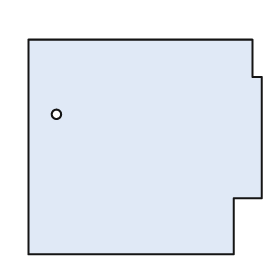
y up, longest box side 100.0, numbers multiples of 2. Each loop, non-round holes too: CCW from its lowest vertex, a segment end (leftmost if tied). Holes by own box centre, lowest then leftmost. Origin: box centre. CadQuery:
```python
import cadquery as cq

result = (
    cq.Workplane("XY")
    .moveTo(-50.0, -46.0)
    .lineTo(38.0, -46.0)
    .lineTo(38.0, -22.0)
    .lineTo(50.0, -22.0)
    .lineTo(50.0, 30.0)
    .lineTo(46.0, 30.0)
    .lineTo(46.0, 46.0)
    .lineTo(-50.0, 46.0)
    .close()
    .moveTo(-38.0, 14.0)
    .circle(2.0)
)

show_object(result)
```